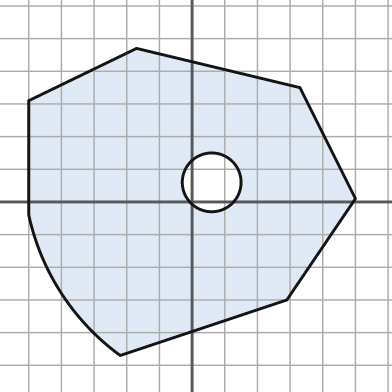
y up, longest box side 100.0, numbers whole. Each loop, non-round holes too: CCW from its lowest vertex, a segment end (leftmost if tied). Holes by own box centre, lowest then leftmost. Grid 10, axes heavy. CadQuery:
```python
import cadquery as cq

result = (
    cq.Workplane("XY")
    .moveTo(-22.0, -47.0)
    .lineTo(29.0, -30.0)
    .lineTo(50.0, 1.0)
    .lineTo(33.0, 35.0)
    .lineTo(-17.0, 47.0)
    .lineTo(-50.0, 31.0)
    .lineTo(-50.0, -4.0)
    .threePointArc((-40.0, -28.0), (-22.0, -47.0))
    .close()
    .moveTo(6.0, 6.0)
    .circle(9.0)
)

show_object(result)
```